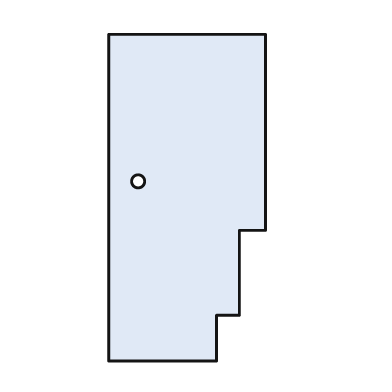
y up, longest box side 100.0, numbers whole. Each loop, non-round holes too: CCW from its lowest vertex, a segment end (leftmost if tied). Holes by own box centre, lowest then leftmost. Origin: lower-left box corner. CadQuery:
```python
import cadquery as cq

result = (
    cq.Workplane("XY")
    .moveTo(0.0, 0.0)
    .lineTo(33.0, 0.0)
    .lineTo(33.0, 14.0)
    .lineTo(40.0, 14.0)
    .lineTo(40.0, 40.0)
    .lineTo(48.0, 40.0)
    .lineTo(48.0, 100.0)
    .lineTo(0.0, 100.0)
    .close()
    .moveTo(9.0, 55.0)
    .circle(2.0)
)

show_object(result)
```